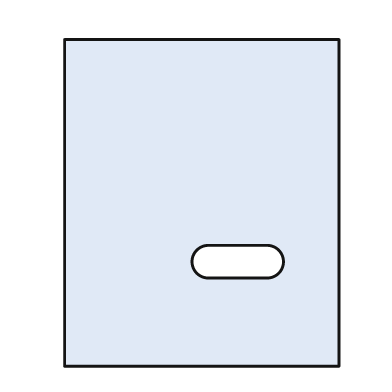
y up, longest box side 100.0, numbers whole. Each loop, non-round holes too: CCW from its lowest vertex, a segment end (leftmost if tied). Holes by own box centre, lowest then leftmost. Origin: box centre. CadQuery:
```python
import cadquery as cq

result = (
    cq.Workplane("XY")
    .moveTo(-42.0, -50.0)
    .lineTo(42.0, -50.0)
    .lineTo(42.0, 50.0)
    .lineTo(-42.0, 50.0)
    .close()
    .moveTo(2.0, -23.0)
    .lineTo(20.0, -23.0)
    .threePointArc((25.0, -18.0), (20.0, -13.0))
    .lineTo(2.0, -13.0)
    .threePointArc((-3.0, -18.0), (2.0, -23.0))
    .close()
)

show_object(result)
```